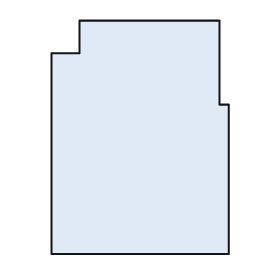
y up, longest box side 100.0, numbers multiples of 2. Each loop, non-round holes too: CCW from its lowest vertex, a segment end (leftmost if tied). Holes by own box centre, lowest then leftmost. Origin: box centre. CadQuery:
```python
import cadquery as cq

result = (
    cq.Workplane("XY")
    .moveTo(-38.0, -50.0)
    .lineTo(38.0, -50.0)
    .lineTo(38.0, 14.0)
    .lineTo(34.0, 14.0)
    .lineTo(34.0, 50.0)
    .lineTo(-26.0, 50.0)
    .lineTo(-26.0, 36.0)
    .lineTo(-38.0, 36.0)
    .close()
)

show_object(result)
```